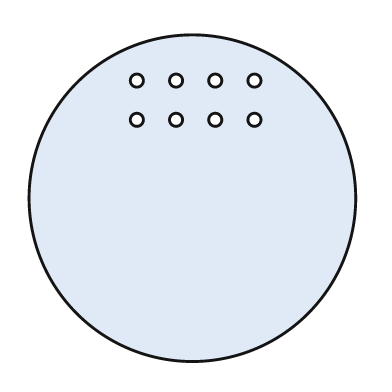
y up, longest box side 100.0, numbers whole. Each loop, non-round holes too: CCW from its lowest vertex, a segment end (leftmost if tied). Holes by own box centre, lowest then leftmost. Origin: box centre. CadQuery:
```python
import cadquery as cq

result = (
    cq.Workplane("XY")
    .moveTo(0.0, 0.0)
    .circle(50.0)
    .moveTo(-17.0, 24.0)
    .circle(2.0)
    .moveTo(-5.0, 24.0)
    .circle(2.0)
    .moveTo(7.0, 24.0)
    .circle(2.0)
    .moveTo(19.0, 24.0)
    .circle(2.0)
    .moveTo(-17.0, 36.0)
    .circle(2.0)
    .moveTo(-5.0, 36.0)
    .circle(2.0)
    .moveTo(7.0, 36.0)
    .circle(2.0)
    .moveTo(19.0, 36.0)
    .circle(2.0)
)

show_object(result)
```